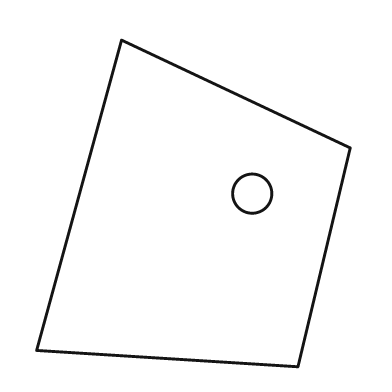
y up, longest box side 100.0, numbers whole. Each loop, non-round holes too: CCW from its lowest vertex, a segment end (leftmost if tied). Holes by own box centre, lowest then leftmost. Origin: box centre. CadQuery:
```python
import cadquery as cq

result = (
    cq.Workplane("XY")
    .moveTo(32.0, -50.0)
    .lineTo(48.0, 17.0)
    .lineTo(-22.0, 50.0)
    .lineTo(-48.0, -45.0)
    .close()
    .moveTo(18.0, 3.0)
    .circle(6.0)
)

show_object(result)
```